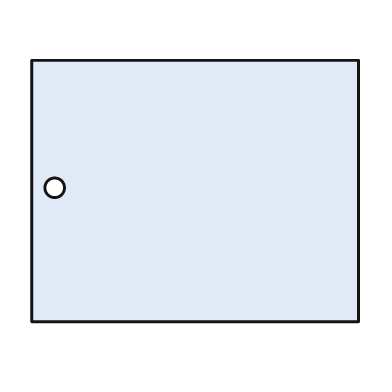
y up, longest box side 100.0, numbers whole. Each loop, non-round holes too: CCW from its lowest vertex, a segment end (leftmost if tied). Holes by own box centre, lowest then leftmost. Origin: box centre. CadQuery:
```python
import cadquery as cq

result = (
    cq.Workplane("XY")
    .moveTo(-50.0, -40.0)
    .lineTo(50.0, -40.0)
    .lineTo(50.0, 40.0)
    .lineTo(-50.0, 40.0)
    .close()
    .moveTo(-43.0, 1.0)
    .circle(3.0)
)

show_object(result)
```